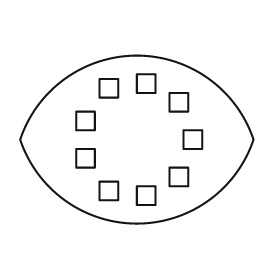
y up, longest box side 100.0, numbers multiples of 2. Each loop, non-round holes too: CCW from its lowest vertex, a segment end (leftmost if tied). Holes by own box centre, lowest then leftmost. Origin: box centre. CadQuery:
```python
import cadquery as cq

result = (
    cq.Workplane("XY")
    .moveTo(-50.0, 0.0)
    .threePointArc((0.0, -36.0), (50.0, 0.0))
    .threePointArc((0.0, 36.0), (-50.0, 0.0))
    .close()
    .moveTo(0.0, -28.0)
    .lineTo(8.0, -28.0)
    .lineTo(8.0, -20.0)
    .lineTo(0.0, -20.0)
    .close()
    .moveTo(-16.0, -26.0)
    .lineTo(-8.0, -26.0)
    .lineTo(-8.0, -18.0)
    .lineTo(-16.0, -18.0)
    .close()
    .moveTo(14.0, -20.0)
    .lineTo(22.0, -20.0)
    .lineTo(22.0, -12.0)
    .lineTo(14.0, -12.0)
    .close()
    .moveTo(-26.0, -12.0)
    .lineTo(-18.0, -12.0)
    .lineTo(-18.0, -4.0)
    .lineTo(-26.0, -4.0)
    .close()
    .moveTo(20.0, -4.0)
    .lineTo(28.0, -4.0)
    .lineTo(28.0, 4.0)
    .lineTo(20.0, 4.0)
    .close()
    .moveTo(-26.0, 4.0)
    .lineTo(-18.0, 4.0)
    .lineTo(-18.0, 12.0)
    .lineTo(-26.0, 12.0)
    .close()
    .moveTo(14.0, 12.0)
    .lineTo(22.0, 12.0)
    .lineTo(22.0, 20.0)
    .lineTo(14.0, 20.0)
    .close()
    .moveTo(-16.0, 18.0)
    .lineTo(-8.0, 18.0)
    .lineTo(-8.0, 26.0)
    .lineTo(-16.0, 26.0)
    .close()
    .moveTo(0.0, 20.0)
    .lineTo(8.0, 20.0)
    .lineTo(8.0, 28.0)
    .lineTo(0.0, 28.0)
    .close()
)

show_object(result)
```